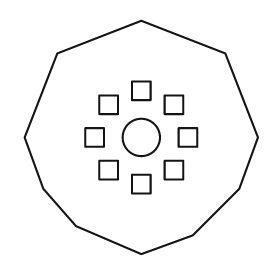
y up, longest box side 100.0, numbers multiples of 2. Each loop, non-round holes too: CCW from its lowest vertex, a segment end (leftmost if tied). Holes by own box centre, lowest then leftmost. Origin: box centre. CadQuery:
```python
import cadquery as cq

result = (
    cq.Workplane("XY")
    .moveTo(0.0, -50.0)
    .lineTo(22.0, -42.0)
    .lineTo(42.0, -22.0)
    .lineTo(50.0, 0.0)
    .lineTo(36.0, 36.0)
    .lineTo(0.0, 50.0)
    .lineTo(-36.0, 36.0)
    .lineTo(-50.0, 0.0)
    .lineTo(-42.0, -22.0)
    .lineTo(-28.0, -38.0)
    .close()
    .moveTo(-4.0, -24.0)
    .lineTo(4.0, -24.0)
    .lineTo(4.0, -16.0)
    .lineTo(-4.0, -16.0)
    .close()
    .moveTo(-18.0, -18.0)
    .lineTo(-10.0, -18.0)
    .lineTo(-10.0, -10.0)
    .lineTo(-18.0, -10.0)
    .close()
    .moveTo(10.0, -18.0)
    .lineTo(18.0, -18.0)
    .lineTo(18.0, -10.0)
    .lineTo(10.0, -10.0)
    .close()
    .moveTo(-24.0, -4.0)
    .lineTo(-16.0, -4.0)
    .lineTo(-16.0, 4.0)
    .lineTo(-24.0, 4.0)
    .close()
    .moveTo(0.0, 0.0)
    .circle(8.0)
    .moveTo(16.0, -4.0)
    .lineTo(24.0, -4.0)
    .lineTo(24.0, 4.0)
    .lineTo(16.0, 4.0)
    .close()
    .moveTo(-18.0, 10.0)
    .lineTo(-10.0, 10.0)
    .lineTo(-10.0, 18.0)
    .lineTo(-18.0, 18.0)
    .close()
    .moveTo(10.0, 10.0)
    .lineTo(18.0, 10.0)
    .lineTo(18.0, 18.0)
    .lineTo(10.0, 18.0)
    .close()
    .moveTo(-4.0, 16.0)
    .lineTo(4.0, 16.0)
    .lineTo(4.0, 24.0)
    .lineTo(-4.0, 24.0)
    .close()
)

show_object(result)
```